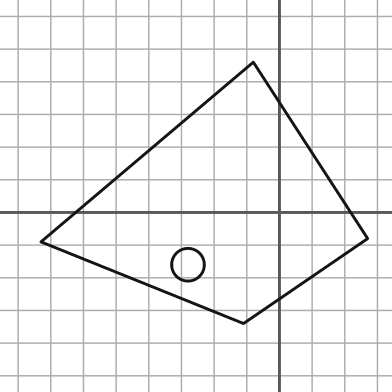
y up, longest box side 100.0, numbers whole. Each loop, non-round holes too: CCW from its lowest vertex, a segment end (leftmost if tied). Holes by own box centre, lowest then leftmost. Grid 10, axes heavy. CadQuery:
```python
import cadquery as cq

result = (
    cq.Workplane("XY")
    .moveTo(-11.0, -34.0)
    .lineTo(27.0, -8.0)
    .lineTo(-8.0, 46.0)
    .lineTo(-73.0, -9.0)
    .close()
    .moveTo(-28.0, -16.0)
    .circle(5.0)
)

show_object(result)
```